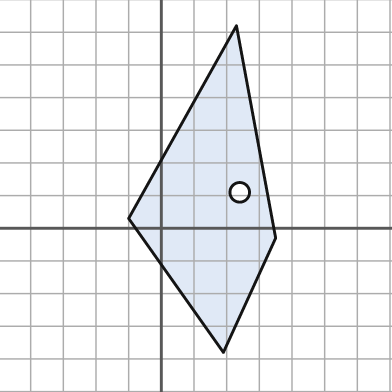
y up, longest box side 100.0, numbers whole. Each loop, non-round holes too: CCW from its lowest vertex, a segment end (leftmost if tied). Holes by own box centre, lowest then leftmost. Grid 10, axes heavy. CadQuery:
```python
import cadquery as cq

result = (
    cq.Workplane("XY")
    .moveTo(19.0, -38.0)
    .lineTo(35.0, -3.0)
    .lineTo(23.0, 62.0)
    .lineTo(-10.0, 3.0)
    .close()
    .moveTo(24.0, 11.0)
    .circle(3.0)
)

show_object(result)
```